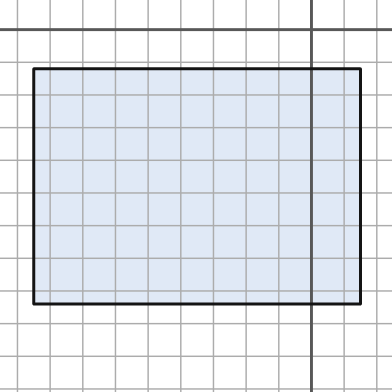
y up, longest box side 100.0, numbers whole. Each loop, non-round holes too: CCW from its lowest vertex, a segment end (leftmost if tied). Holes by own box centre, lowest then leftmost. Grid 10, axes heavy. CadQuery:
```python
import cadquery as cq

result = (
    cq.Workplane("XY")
    .moveTo(-85.0, -84.0)
    .lineTo(15.0, -84.0)
    .lineTo(15.0, -12.0)
    .lineTo(-85.0, -12.0)
    .close()
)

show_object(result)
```